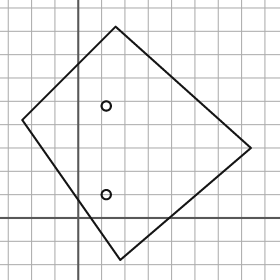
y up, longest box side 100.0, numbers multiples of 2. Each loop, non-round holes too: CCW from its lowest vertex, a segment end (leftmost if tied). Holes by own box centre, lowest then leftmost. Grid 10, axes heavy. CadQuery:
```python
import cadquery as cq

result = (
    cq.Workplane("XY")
    .moveTo(18.0, -18.0)
    .lineTo(74.0, 30.0)
    .lineTo(16.0, 82.0)
    .lineTo(-24.0, 42.0)
    .close()
    .moveTo(12.0, 10.0)
    .circle(2.0)
    .moveTo(12.0, 48.0)
    .circle(2.0)
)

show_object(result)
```